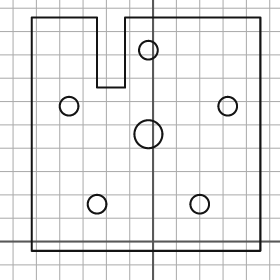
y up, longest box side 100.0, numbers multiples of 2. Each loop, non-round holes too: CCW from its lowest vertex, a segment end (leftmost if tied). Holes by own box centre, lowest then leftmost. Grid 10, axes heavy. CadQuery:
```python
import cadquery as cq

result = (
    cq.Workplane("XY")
    .moveTo(-52.0, -4.0)
    .lineTo(46.0, -4.0)
    .lineTo(46.0, 96.0)
    .lineTo(-12.0, 96.0)
    .lineTo(-12.0, 66.0)
    .lineTo(-24.0, 66.0)
    .lineTo(-24.0, 96.0)
    .lineTo(-52.0, 96.0)
    .close()
    .moveTo(-24.0, 16.0)
    .circle(4.0)
    .moveTo(20.0, 16.0)
    .circle(4.0)
    .moveTo(-2.0, 46.0)
    .circle(6.0)
    .moveTo(-36.0, 58.0)
    .circle(4.0)
    .moveTo(32.0, 58.0)
    .circle(4.0)
    .moveTo(-2.0, 82.0)
    .circle(4.0)
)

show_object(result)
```